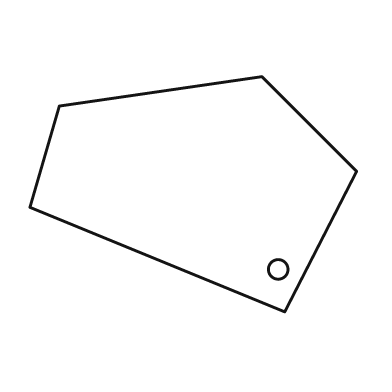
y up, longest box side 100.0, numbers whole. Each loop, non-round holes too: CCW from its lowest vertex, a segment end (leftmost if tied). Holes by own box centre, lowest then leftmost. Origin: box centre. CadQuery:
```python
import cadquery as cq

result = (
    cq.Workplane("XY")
    .moveTo(28.0, -36.0)
    .lineTo(50.0, 7.0)
    .lineTo(21.0, 36.0)
    .lineTo(-41.0, 27.0)
    .lineTo(-50.0, -4.0)
    .close()
    .moveTo(26.0, -23.0)
    .circle(3.0)
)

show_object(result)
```